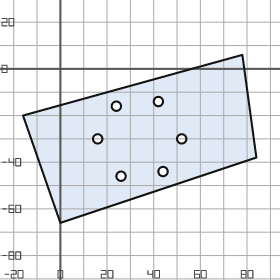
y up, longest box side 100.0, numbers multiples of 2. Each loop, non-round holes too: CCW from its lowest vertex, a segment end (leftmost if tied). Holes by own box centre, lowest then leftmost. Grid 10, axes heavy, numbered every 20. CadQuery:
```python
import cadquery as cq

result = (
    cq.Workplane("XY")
    .moveTo(0.0, -66.0)
    .lineTo(84.0, -38.0)
    .lineTo(78.0, 6.0)
    .lineTo(-16.0, -20.0)
    .close()
    .moveTo(26.0, -46.0)
    .circle(2.0)
    .moveTo(44.0, -44.0)
    .circle(2.0)
    .moveTo(16.0, -30.0)
    .circle(2.0)
    .moveTo(52.0, -30.0)
    .circle(2.0)
    .moveTo(24.0, -16.0)
    .circle(2.0)
    .moveTo(42.0, -14.0)
    .circle(2.0)
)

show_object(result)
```